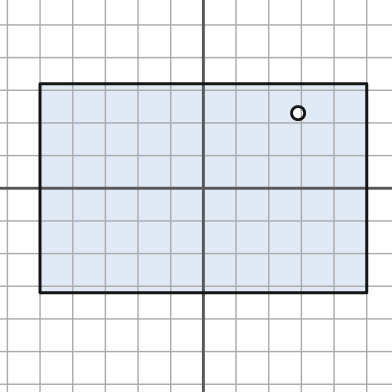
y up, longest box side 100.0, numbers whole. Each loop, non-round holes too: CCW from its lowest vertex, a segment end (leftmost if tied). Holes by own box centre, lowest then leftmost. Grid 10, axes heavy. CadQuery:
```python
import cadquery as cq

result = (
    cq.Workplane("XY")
    .moveTo(-50.0, -32.0)
    .lineTo(50.0, -32.0)
    .lineTo(50.0, 32.0)
    .lineTo(-50.0, 32.0)
    .close()
    .moveTo(29.0, 23.0)
    .circle(2.0)
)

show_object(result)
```